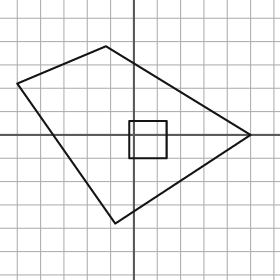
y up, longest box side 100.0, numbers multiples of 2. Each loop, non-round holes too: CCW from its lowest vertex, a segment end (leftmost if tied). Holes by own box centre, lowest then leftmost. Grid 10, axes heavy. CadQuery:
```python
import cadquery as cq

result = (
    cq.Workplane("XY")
    .moveTo(-8.0, -38.0)
    .lineTo(50.0, 0.0)
    .lineTo(-12.0, 38.0)
    .lineTo(-50.0, 22.0)
    .close()
    .moveTo(-2.0, -10.0)
    .lineTo(14.0, -10.0)
    .lineTo(14.0, 6.0)
    .lineTo(-2.0, 6.0)
    .close()
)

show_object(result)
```